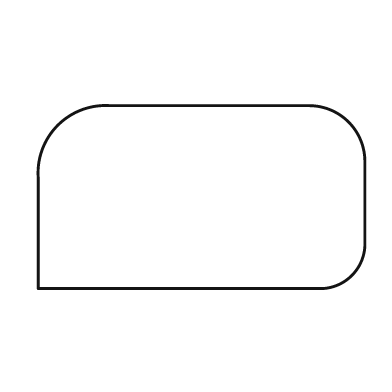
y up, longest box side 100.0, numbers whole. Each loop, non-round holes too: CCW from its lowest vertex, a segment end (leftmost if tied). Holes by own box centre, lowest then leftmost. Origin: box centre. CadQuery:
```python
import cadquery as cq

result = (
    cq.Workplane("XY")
    .moveTo(-50.0, -28.0)
    .lineTo(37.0, -28.0)
    .threePointArc((46.0, -24.0), (50.0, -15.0))
    .lineTo(50.0, 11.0)
    .threePointArc((45.0, 23.0), (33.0, 28.0))
    .lineTo(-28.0, 28.0)
    .threePointArc((-44.0, 22.0), (-50.0, 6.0))
    .close()
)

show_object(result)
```